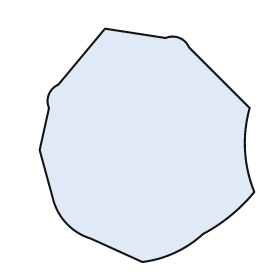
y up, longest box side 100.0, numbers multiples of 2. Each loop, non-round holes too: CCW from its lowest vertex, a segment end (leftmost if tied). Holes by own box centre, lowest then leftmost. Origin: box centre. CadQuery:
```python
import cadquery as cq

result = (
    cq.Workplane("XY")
    .moveTo(-2.0, -50.0)
    .threePointArc((12.0, -46.0), (24.0, -38.0))
    .threePointArc((36.0, -30.0), (46.0, -20.0))
    .threePointArc((42.0, -2.0), (44.0, 16.0))
    .lineTo(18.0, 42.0)
    .threePointArc((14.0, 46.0), (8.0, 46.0))
    .lineTo(-18.0, 50.0)
    .lineTo(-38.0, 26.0)
    .threePointArc((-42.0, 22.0), (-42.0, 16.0))
    .lineTo(-46.0, -2.0)
    .lineTo(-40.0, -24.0)
    .threePointArc((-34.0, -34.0), (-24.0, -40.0))
    .close()
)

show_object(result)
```